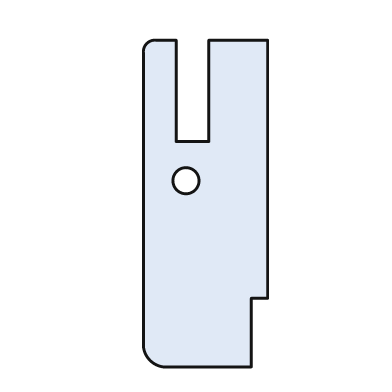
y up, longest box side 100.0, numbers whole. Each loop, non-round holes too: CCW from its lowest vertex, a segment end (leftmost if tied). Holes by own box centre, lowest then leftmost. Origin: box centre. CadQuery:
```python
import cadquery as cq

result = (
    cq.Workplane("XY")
    .moveTo(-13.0, -50.0)
    .lineTo(14.0, -50.0)
    .lineTo(14.0, -29.0)
    .lineTo(19.0, -29.0)
    .lineTo(19.0, 50.0)
    .lineTo(1.0, 50.0)
    .lineTo(1.0, 19.0)
    .lineTo(-9.0, 19.0)
    .lineTo(-9.0, 50.0)
    .lineTo(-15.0, 50.0)
    .threePointArc((-18.0, 49.0), (-19.0, 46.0))
    .lineTo(-19.0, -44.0)
    .threePointArc((-17.0, -48.0), (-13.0, -50.0))
    .close()
    .moveTo(-6.0, 7.0)
    .circle(4.0)
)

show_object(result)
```